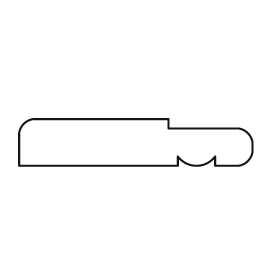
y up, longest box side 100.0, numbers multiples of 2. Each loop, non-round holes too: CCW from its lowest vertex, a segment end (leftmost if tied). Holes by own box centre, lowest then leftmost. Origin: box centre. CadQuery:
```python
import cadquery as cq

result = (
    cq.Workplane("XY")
    .moveTo(-50.0, -10.0)
    .lineTo(18.0, -10.0)
    .lineTo(18.0, -6.0)
    .threePointArc((26.0, -10.0), (34.0, -6.0))
    .lineTo(34.0, -10.0)
    .lineTo(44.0, -10.0)
    .threePointArc((48.0, -8.0), (50.0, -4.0))
    .lineTo(50.0, 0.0)
    .threePointArc((48.0, 4.0), (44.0, 6.0))
    .lineTo(14.0, 6.0)
    .lineTo(14.0, 10.0)
    .lineTo(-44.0, 10.0)
    .threePointArc((-48.0, 8.0), (-50.0, 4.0))
    .close()
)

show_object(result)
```